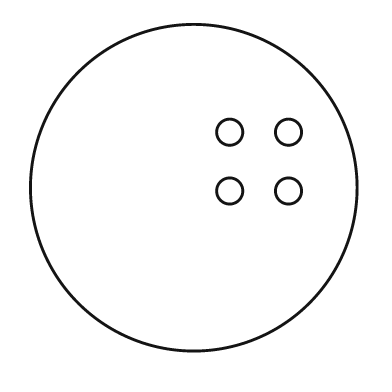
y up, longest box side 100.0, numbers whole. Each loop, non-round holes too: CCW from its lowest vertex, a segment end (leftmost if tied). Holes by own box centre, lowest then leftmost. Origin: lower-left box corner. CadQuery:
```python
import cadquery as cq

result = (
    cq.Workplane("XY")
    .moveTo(50.0, 50.0)
    .circle(50.0)
    .moveTo(61.0, 49.0)
    .circle(4.0)
    .moveTo(79.0, 49.0)
    .circle(4.0)
    .moveTo(61.0, 67.0)
    .circle(4.0)
    .moveTo(79.0, 67.0)
    .circle(4.0)
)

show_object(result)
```